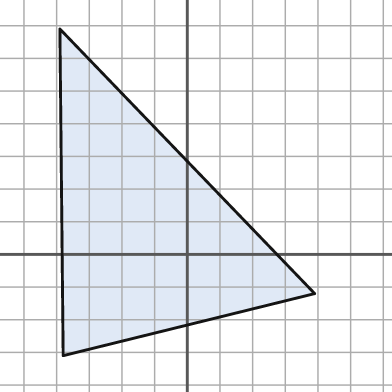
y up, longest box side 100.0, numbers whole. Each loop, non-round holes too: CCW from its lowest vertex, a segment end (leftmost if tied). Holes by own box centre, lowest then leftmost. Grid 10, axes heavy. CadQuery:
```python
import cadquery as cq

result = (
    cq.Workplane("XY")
    .moveTo(-38.0, -31.0)
    .lineTo(39.0, -12.0)
    .lineTo(-39.0, 69.0)
    .close()
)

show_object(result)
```